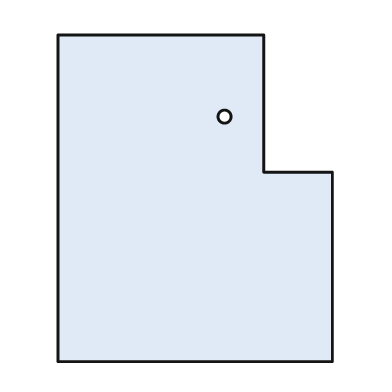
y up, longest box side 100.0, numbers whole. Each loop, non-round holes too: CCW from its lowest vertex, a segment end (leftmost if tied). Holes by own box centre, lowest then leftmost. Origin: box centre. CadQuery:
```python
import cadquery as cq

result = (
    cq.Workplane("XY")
    .moveTo(-42.0, -50.0)
    .lineTo(42.0, -50.0)
    .lineTo(42.0, 8.0)
    .lineTo(21.0, 8.0)
    .lineTo(21.0, 50.0)
    .lineTo(-42.0, 50.0)
    .close()
    .moveTo(9.0, 25.0)
    .circle(2.0)
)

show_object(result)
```